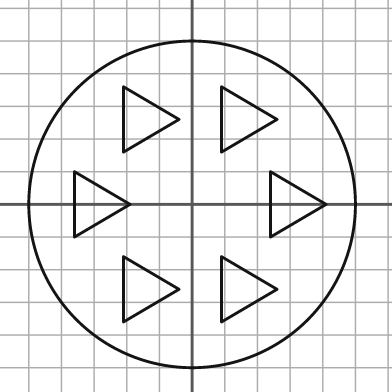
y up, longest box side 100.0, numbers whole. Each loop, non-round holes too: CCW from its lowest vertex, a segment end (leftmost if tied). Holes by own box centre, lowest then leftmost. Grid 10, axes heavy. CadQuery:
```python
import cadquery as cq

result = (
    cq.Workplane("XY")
    .moveTo(0.0, 0.0)
    .circle(50.0)
    .moveTo(-21.0, -36.0)
    .lineTo(-4.0, -26.0)
    .lineTo(-21.0, -16.0)
    .close()
    .moveTo(9.0, -36.0)
    .lineTo(26.0, -26.0)
    .lineTo(9.0, -16.0)
    .close()
    .moveTo(-36.0, -10.0)
    .lineTo(-19.0, 0.0)
    .lineTo(-36.0, 10.0)
    .close()
    .moveTo(24.0, -10.0)
    .lineTo(41.0, 0.0)
    .lineTo(24.0, 10.0)
    .close()
    .moveTo(-21.0, 16.0)
    .lineTo(-4.0, 26.0)
    .lineTo(-21.0, 36.0)
    .close()
    .moveTo(9.0, 16.0)
    .lineTo(26.0, 26.0)
    .lineTo(9.0, 36.0)
    .close()
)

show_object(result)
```